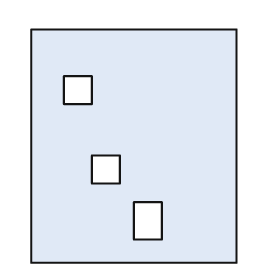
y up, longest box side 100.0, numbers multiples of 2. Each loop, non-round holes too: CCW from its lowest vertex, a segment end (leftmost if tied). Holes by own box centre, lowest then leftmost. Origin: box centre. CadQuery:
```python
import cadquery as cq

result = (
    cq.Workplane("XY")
    .moveTo(-44.0, -50.0)
    .lineTo(44.0, -50.0)
    .lineTo(44.0, 50.0)
    .lineTo(-44.0, 50.0)
    .close()
    .moveTo(0.0, -40.0)
    .lineTo(12.0, -40.0)
    .lineTo(12.0, -24.0)
    .lineTo(0.0, -24.0)
    .close()
    .moveTo(-18.0, -16.0)
    .lineTo(-6.0, -16.0)
    .lineTo(-6.0, -4.0)
    .lineTo(-18.0, -4.0)
    .close()
    .moveTo(-30.0, 18.0)
    .lineTo(-18.0, 18.0)
    .lineTo(-18.0, 30.0)
    .lineTo(-30.0, 30.0)
    .close()
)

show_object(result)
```